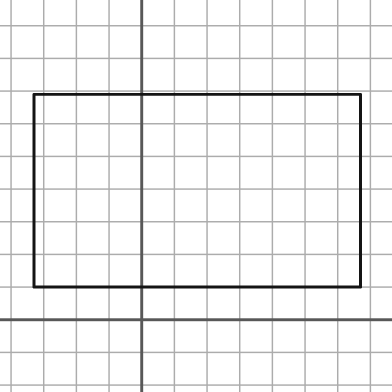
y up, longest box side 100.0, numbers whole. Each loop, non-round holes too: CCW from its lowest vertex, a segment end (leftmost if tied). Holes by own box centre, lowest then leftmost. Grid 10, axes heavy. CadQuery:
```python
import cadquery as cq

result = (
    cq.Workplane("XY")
    .moveTo(-33.0, 10.0)
    .lineTo(67.0, 10.0)
    .lineTo(67.0, 69.0)
    .lineTo(-33.0, 69.0)
    .close()
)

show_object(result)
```